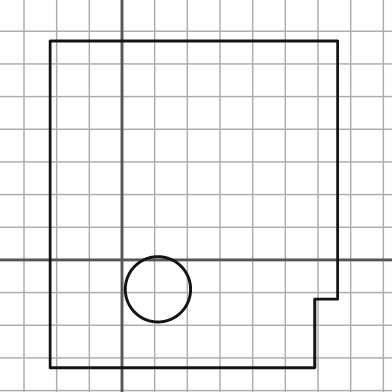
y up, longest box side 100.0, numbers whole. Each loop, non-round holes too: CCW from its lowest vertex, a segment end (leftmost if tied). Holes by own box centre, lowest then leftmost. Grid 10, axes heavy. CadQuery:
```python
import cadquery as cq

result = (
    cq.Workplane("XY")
    .moveTo(-22.0, -33.0)
    .lineTo(59.0, -33.0)
    .lineTo(59.0, -12.0)
    .lineTo(66.0, -12.0)
    .lineTo(66.0, 67.0)
    .lineTo(-22.0, 67.0)
    .close()
    .moveTo(11.0, -9.0)
    .circle(10.0)
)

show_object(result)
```